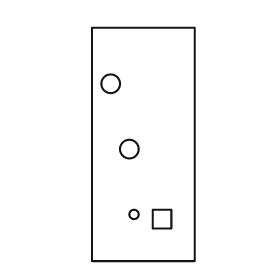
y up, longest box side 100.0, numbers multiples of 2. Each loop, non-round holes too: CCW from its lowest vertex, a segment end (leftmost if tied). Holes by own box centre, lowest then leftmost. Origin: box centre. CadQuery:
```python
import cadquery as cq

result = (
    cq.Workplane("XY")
    .moveTo(-22.0, -50.0)
    .lineTo(22.0, -50.0)
    .lineTo(22.0, 50.0)
    .lineTo(-22.0, 50.0)
    .close()
    .moveTo(4.0, -36.0)
    .lineTo(12.0, -36.0)
    .lineTo(12.0, -28.0)
    .lineTo(4.0, -28.0)
    .close()
    .moveTo(-4.0, -30.0)
    .circle(2.0)
    .moveTo(-6.0, -2.0)
    .circle(4.0)
    .moveTo(-14.0, 26.0)
    .circle(4.0)
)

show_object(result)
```